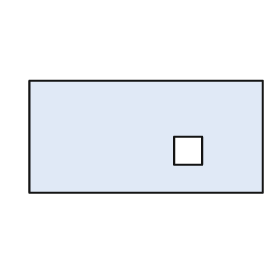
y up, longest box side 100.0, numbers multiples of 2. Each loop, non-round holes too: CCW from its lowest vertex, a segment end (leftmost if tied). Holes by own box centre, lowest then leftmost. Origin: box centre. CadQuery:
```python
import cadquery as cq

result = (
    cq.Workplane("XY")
    .moveTo(-50.0, -24.0)
    .lineTo(50.0, -24.0)
    .lineTo(50.0, 24.0)
    .lineTo(-50.0, 24.0)
    .close()
    .moveTo(12.0, -12.0)
    .lineTo(24.0, -12.0)
    .lineTo(24.0, 0.0)
    .lineTo(12.0, 0.0)
    .close()
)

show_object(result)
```